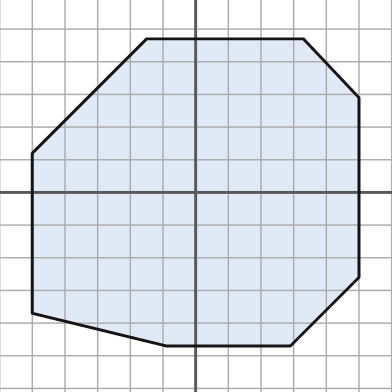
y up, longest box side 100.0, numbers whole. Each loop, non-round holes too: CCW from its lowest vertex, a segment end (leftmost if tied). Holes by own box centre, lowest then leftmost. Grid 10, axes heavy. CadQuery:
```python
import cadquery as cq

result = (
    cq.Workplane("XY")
    .moveTo(-9.0, -47.0)
    .lineTo(29.0, -47.0)
    .lineTo(50.0, -26.0)
    .lineTo(50.0, 29.0)
    .lineTo(33.0, 47.0)
    .lineTo(-15.0, 47.0)
    .lineTo(-50.0, 12.0)
    .lineTo(-50.0, -37.0)
    .close()
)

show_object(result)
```